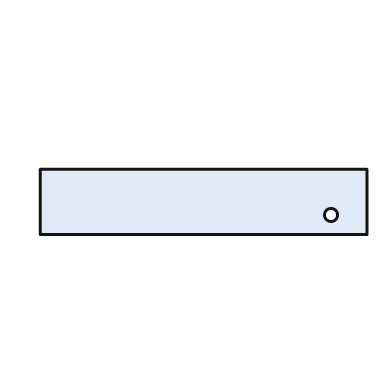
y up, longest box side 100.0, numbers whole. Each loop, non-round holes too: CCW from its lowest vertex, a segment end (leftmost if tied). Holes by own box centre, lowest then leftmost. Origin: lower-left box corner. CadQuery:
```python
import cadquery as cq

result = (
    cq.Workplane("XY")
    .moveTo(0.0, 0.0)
    .lineTo(100.0, 0.0)
    .lineTo(100.0, 20.0)
    .lineTo(0.0, 20.0)
    .close()
    .moveTo(89.0, 6.0)
    .circle(2.0)
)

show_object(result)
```